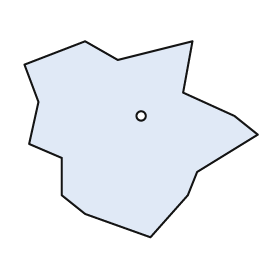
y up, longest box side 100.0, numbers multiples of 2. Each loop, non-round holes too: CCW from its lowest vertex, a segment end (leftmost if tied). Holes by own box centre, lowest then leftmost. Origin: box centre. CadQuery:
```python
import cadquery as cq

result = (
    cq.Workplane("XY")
    .moveTo(4.0, -42.0)
    .lineTo(20.0, -24.0)
    .lineTo(24.0, -14.0)
    .lineTo(50.0, 2.0)
    .lineTo(40.0, 10.0)
    .lineTo(18.0, 20.0)
    .lineTo(22.0, 42.0)
    .lineTo(-10.0, 34.0)
    .lineTo(-24.0, 42.0)
    .lineTo(-50.0, 32.0)
    .lineTo(-44.0, 16.0)
    .lineTo(-48.0, -2.0)
    .lineTo(-34.0, -8.0)
    .lineTo(-34.0, -24.0)
    .lineTo(-24.0, -32.0)
    .close()
    .moveTo(0.0, 10.0)
    .circle(2.0)
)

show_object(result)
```